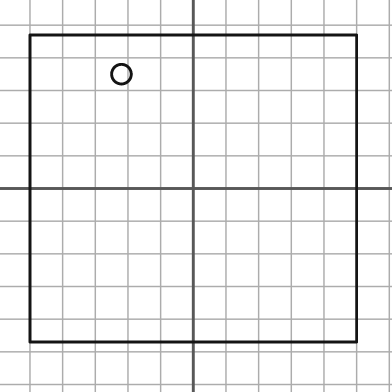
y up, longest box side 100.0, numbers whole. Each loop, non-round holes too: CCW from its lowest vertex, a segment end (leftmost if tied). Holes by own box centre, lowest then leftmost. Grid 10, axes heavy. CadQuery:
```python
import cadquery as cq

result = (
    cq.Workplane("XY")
    .moveTo(-50.0, -47.0)
    .lineTo(50.0, -47.0)
    .lineTo(50.0, 47.0)
    .lineTo(-50.0, 47.0)
    .close()
    .moveTo(-22.0, 35.0)
    .circle(3.0)
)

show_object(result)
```